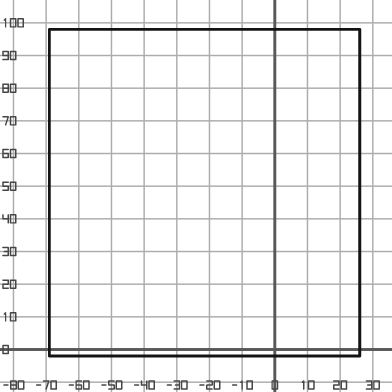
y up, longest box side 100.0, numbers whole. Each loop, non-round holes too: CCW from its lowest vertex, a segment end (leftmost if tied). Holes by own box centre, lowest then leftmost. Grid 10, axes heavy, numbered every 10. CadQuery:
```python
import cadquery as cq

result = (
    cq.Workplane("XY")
    .moveTo(-69.0, -2.0)
    .lineTo(26.0, -2.0)
    .lineTo(26.0, 98.0)
    .lineTo(-69.0, 98.0)
    .close()
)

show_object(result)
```